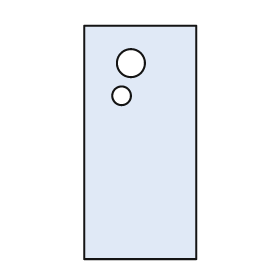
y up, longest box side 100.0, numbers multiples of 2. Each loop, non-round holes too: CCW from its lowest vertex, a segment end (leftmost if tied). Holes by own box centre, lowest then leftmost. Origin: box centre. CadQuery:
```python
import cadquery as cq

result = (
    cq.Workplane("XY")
    .moveTo(-24.0, -50.0)
    .lineTo(24.0, -50.0)
    .lineTo(24.0, 50.0)
    .lineTo(-24.0, 50.0)
    .close()
    .moveTo(-8.0, 20.0)
    .circle(4.0)
    .moveTo(-4.0, 34.0)
    .circle(6.0)
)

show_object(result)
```